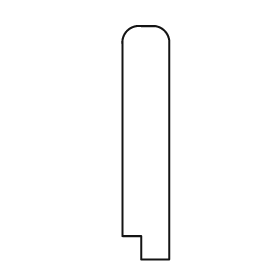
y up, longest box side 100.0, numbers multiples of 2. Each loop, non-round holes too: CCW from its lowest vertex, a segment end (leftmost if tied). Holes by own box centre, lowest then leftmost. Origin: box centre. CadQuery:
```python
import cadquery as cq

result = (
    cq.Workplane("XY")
    .moveTo(-2.0, -50.0)
    .lineTo(10.0, -50.0)
    .lineTo(10.0, 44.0)
    .threePointArc((8.0, 48.0), (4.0, 50.0))
    .lineTo(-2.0, 50.0)
    .threePointArc((-8.0, 48.0), (-10.0, 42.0))
    .lineTo(-10.0, -40.0)
    .lineTo(-2.0, -40.0)
    .close()
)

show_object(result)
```